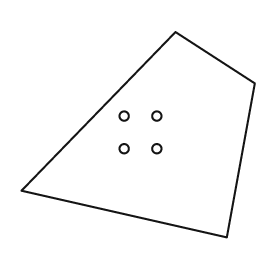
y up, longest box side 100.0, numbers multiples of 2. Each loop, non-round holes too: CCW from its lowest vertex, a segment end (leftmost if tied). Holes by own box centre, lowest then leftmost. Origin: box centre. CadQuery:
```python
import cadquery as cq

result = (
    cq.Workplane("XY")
    .moveTo(38.0, -44.0)
    .lineTo(50.0, 22.0)
    .lineTo(16.0, 44.0)
    .lineTo(-50.0, -24.0)
    .close()
    .moveTo(-6.0, -6.0)
    .circle(2.0)
    .moveTo(8.0, -6.0)
    .circle(2.0)
    .moveTo(-6.0, 8.0)
    .circle(2.0)
    .moveTo(8.0, 8.0)
    .circle(2.0)
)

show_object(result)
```